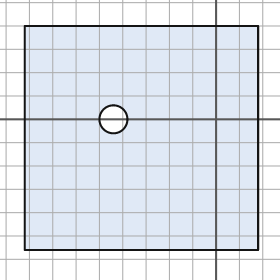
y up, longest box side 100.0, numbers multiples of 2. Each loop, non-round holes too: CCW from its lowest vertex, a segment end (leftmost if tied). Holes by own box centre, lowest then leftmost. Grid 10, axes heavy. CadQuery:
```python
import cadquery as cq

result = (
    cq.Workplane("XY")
    .moveTo(-82.0, -56.0)
    .lineTo(18.0, -56.0)
    .lineTo(18.0, 40.0)
    .lineTo(-82.0, 40.0)
    .close()
    .moveTo(-44.0, 0.0)
    .circle(6.0)
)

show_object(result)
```